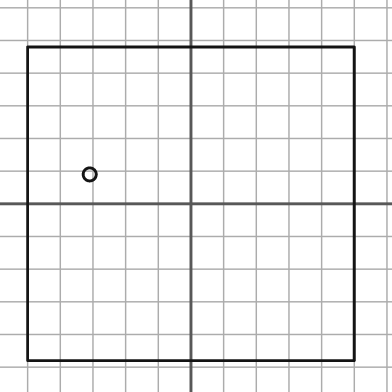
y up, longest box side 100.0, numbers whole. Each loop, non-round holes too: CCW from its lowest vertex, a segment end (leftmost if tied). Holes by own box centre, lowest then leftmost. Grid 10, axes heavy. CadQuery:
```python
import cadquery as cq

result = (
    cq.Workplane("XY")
    .moveTo(-50.0, -48.0)
    .lineTo(50.0, -48.0)
    .lineTo(50.0, 48.0)
    .lineTo(-50.0, 48.0)
    .close()
    .moveTo(-31.0, 9.0)
    .circle(2.0)
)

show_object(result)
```